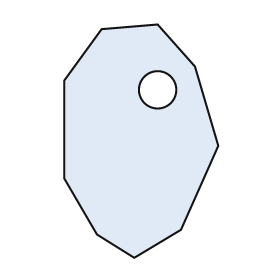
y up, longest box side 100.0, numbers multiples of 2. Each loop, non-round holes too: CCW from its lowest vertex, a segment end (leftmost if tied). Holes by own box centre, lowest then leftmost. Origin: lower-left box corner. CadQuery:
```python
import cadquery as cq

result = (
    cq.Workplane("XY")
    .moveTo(30.0, 0.0)
    .lineTo(50.0, 12.0)
    .lineTo(66.0, 48.0)
    .lineTo(56.0, 82.0)
    .lineTo(40.0, 100.0)
    .lineTo(16.0, 98.0)
    .lineTo(0.0, 76.0)
    .lineTo(0.0, 34.0)
    .lineTo(14.0, 10.0)
    .close()
    .moveTo(40.0, 72.0)
    .circle(8.0)
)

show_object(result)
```